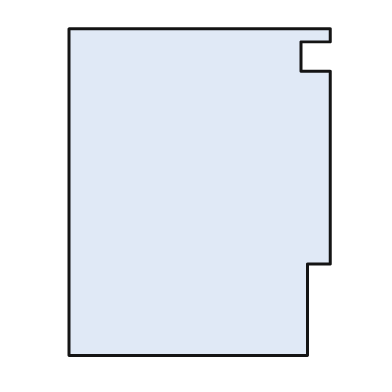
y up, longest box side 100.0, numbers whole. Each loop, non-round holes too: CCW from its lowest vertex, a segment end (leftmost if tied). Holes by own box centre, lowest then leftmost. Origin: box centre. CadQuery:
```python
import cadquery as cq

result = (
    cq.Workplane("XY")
    .moveTo(-40.0, -50.0)
    .lineTo(33.0, -50.0)
    .lineTo(33.0, -22.0)
    .lineTo(40.0, -22.0)
    .lineTo(40.0, 37.0)
    .lineTo(31.0, 37.0)
    .lineTo(31.0, 46.0)
    .lineTo(40.0, 46.0)
    .lineTo(40.0, 50.0)
    .lineTo(-40.0, 50.0)
    .close()
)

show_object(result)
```